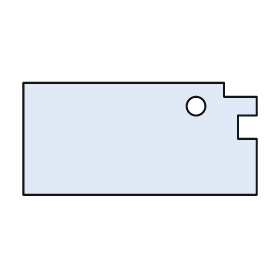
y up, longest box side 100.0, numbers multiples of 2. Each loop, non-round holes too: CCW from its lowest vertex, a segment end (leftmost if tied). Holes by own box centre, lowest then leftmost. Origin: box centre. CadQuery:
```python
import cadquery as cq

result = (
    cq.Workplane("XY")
    .moveTo(-50.0, -24.0)
    .lineTo(50.0, -24.0)
    .lineTo(50.0, 0.0)
    .lineTo(42.0, 0.0)
    .lineTo(42.0, 10.0)
    .lineTo(50.0, 10.0)
    .lineTo(50.0, 18.0)
    .lineTo(36.0, 18.0)
    .lineTo(36.0, 24.0)
    .lineTo(-50.0, 24.0)
    .close()
    .moveTo(24.0, 14.0)
    .circle(4.0)
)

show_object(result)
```